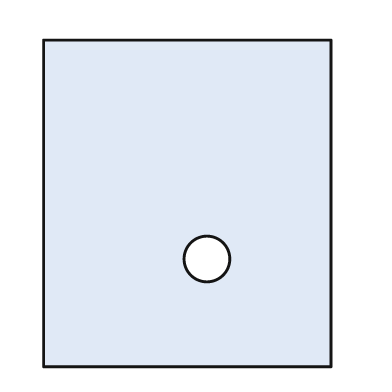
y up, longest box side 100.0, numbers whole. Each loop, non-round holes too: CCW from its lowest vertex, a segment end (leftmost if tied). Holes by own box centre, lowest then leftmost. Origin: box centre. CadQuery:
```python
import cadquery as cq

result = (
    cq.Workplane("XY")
    .moveTo(-44.0, -50.0)
    .lineTo(44.0, -50.0)
    .lineTo(44.0, 50.0)
    .lineTo(-44.0, 50.0)
    .close()
    .moveTo(6.0, -17.0)
    .circle(7.0)
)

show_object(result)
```